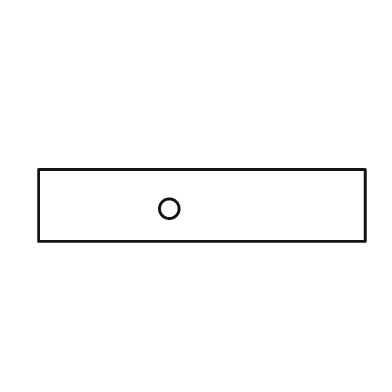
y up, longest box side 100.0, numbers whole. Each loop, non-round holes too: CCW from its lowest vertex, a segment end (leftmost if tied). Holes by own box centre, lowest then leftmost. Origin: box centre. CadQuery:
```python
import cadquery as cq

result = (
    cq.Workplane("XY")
    .moveTo(-50.0, -11.0)
    .lineTo(50.0, -11.0)
    .lineTo(50.0, 11.0)
    .lineTo(-50.0, 11.0)
    .close()
    .moveTo(-10.0, -1.0)
    .circle(3.0)
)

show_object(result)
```